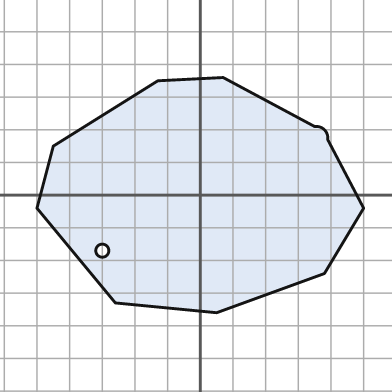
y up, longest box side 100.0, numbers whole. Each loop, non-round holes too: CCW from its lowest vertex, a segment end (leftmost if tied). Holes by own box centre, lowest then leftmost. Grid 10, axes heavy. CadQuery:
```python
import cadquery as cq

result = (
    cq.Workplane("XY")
    .moveTo(5.0, -36.0)
    .lineTo(38.0, -24.0)
    .lineTo(50.0, -4.0)
    .lineTo(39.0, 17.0)
    .threePointArc((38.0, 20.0), (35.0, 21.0))
    .lineTo(7.0, 36.0)
    .lineTo(-13.0, 35.0)
    .lineTo(-45.0, 15.0)
    .lineTo(-50.0, -4.0)
    .lineTo(-26.0, -33.0)
    .close()
    .moveTo(-30.0, -17.0)
    .circle(2.0)
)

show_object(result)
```